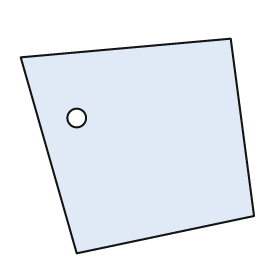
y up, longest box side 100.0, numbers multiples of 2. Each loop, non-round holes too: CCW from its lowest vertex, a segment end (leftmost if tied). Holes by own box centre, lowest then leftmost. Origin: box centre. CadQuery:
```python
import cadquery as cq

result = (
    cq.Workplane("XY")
    .moveTo(-26.0, -46.0)
    .lineTo(50.0, -30.0)
    .lineTo(40.0, 46.0)
    .lineTo(-50.0, 38.0)
    .close()
    .moveTo(-26.0, 12.0)
    .circle(4.0)
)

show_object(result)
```